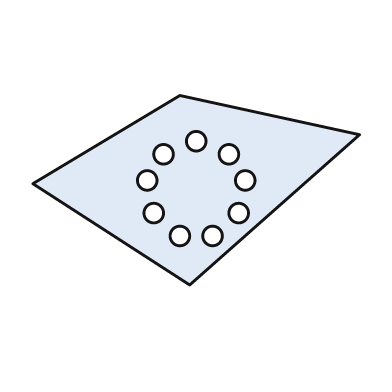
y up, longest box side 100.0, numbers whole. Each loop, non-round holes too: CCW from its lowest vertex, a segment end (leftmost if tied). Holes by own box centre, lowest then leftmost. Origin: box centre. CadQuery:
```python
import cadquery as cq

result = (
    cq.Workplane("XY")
    .moveTo(-2.0, -29.0)
    .lineTo(50.0, 17.0)
    .lineTo(-5.0, 29.0)
    .lineTo(-50.0, 2.0)
    .close()
    .moveTo(-5.0, -14.0)
    .circle(3.0)
    .moveTo(5.0, -14.0)
    .circle(3.0)
    .moveTo(-13.0, -7.0)
    .circle(3.0)
    .moveTo(13.0, -7.0)
    .circle(3.0)
    .moveTo(-15.0, 3.0)
    .circle(3.0)
    .moveTo(15.0, 3.0)
    .circle(3.0)
    .moveTo(-10.0, 11.0)
    .circle(3.0)
    .moveTo(10.0, 11.0)
    .circle(3.0)
    .moveTo(0.0, 15.0)
    .circle(3.0)
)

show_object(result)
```